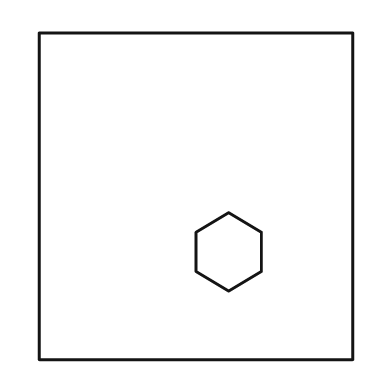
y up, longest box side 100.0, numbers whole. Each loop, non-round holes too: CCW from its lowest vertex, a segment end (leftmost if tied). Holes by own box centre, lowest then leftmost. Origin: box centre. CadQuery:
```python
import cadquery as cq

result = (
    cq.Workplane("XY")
    .moveTo(-48.0, -50.0)
    .lineTo(48.0, -50.0)
    .lineTo(48.0, 50.0)
    .lineTo(-48.0, 50.0)
    .close()
    .moveTo(10.0, -29.0)
    .lineTo(20.0, -23.0)
    .lineTo(20.0, -11.0)
    .lineTo(10.0, -5.0)
    .lineTo(0.0, -11.0)
    .lineTo(0.0, -23.0)
    .close()
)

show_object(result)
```